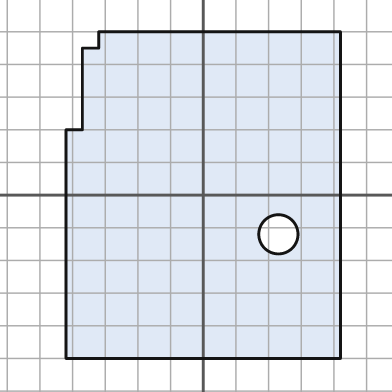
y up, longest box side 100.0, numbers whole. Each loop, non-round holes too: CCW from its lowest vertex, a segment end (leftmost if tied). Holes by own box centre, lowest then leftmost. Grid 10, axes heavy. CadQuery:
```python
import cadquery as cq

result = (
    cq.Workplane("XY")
    .moveTo(-42.0, -50.0)
    .lineTo(42.0, -50.0)
    .lineTo(42.0, 50.0)
    .lineTo(-32.0, 50.0)
    .lineTo(-32.0, 45.0)
    .lineTo(-37.0, 45.0)
    .lineTo(-37.0, 20.0)
    .lineTo(-42.0, 20.0)
    .close()
    .moveTo(23.0, -12.0)
    .circle(6.0)
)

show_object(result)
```